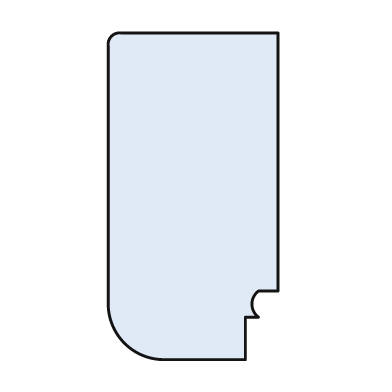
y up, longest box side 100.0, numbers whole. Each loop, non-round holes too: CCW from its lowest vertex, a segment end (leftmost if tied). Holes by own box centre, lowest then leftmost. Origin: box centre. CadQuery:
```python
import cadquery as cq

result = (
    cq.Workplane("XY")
    .moveTo(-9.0, -50.0)
    .lineTo(16.0, -50.0)
    .lineTo(16.0, -37.0)
    .lineTo(20.0, -37.0)
    .threePointArc((18.0, -33.0), (20.0, -29.0))
    .lineTo(26.0, -29.0)
    .lineTo(26.0, 50.0)
    .lineTo(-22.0, 50.0)
    .threePointArc((-25.0, 49.0), (-26.0, 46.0))
    .lineTo(-26.0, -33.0)
    .threePointArc((-21.0, -45.0), (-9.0, -50.0))
    .close()
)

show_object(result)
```